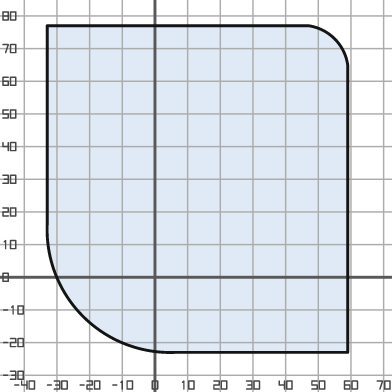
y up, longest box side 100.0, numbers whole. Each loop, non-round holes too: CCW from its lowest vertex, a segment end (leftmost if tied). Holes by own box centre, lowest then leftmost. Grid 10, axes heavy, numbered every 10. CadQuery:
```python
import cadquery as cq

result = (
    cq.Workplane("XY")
    .moveTo(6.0, -23.0)
    .lineTo(59.0, -23.0)
    .lineTo(59.0, 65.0)
    .threePointArc((55.0, 73.0), (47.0, 77.0))
    .lineTo(-33.0, 77.0)
    .lineTo(-33.0, 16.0)
    .threePointArc((-22.0, -12.0), (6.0, -23.0))
    .close()
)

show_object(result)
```